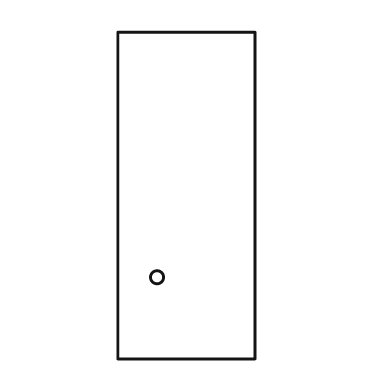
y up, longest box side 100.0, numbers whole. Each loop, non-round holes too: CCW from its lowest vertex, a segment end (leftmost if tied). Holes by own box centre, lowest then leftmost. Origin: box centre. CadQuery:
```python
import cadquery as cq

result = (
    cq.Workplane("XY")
    .moveTo(-21.0, -50.0)
    .lineTo(21.0, -50.0)
    .lineTo(21.0, 50.0)
    .lineTo(-21.0, 50.0)
    .close()
    .moveTo(-9.0, -25.0)
    .circle(2.0)
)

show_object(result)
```